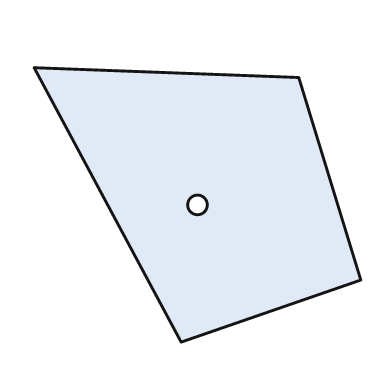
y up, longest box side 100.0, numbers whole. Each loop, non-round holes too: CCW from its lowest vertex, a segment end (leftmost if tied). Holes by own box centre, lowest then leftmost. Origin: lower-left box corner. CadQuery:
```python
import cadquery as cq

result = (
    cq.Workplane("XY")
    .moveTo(45.0, 0.0)
    .lineTo(100.0, 19.0)
    .lineTo(81.0, 81.0)
    .lineTo(0.0, 84.0)
    .close()
    .moveTo(50.0, 42.0)
    .circle(3.0)
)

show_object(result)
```